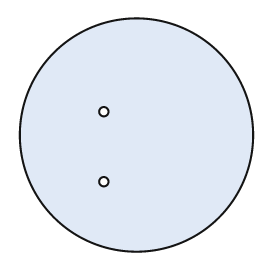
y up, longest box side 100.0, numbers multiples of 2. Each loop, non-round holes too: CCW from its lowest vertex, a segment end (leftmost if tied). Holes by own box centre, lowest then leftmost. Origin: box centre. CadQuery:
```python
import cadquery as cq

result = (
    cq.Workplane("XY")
    .moveTo(0.0, 0.0)
    .circle(50.0)
    .moveTo(-14.0, -20.0)
    .circle(2.0)
    .moveTo(-14.0, 10.0)
    .circle(2.0)
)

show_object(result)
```